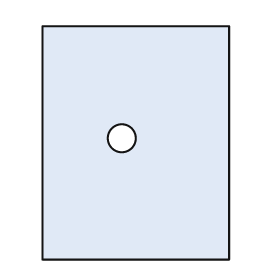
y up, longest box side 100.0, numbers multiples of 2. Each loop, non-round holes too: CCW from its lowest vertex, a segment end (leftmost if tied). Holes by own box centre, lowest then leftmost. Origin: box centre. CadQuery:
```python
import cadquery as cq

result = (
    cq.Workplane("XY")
    .moveTo(-40.0, -50.0)
    .lineTo(40.0, -50.0)
    .lineTo(40.0, 50.0)
    .lineTo(-40.0, 50.0)
    .close()
    .moveTo(-6.0, 2.0)
    .circle(6.0)
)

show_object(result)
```